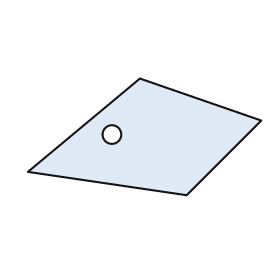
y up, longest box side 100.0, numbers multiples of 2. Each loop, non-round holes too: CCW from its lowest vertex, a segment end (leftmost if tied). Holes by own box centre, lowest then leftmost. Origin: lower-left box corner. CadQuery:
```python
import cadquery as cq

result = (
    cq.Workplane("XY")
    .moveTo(68.0, 0.0)
    .lineTo(100.0, 32.0)
    .lineTo(48.0, 50.0)
    .lineTo(0.0, 10.0)
    .close()
    .moveTo(36.0, 26.0)
    .circle(4.0)
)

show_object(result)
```